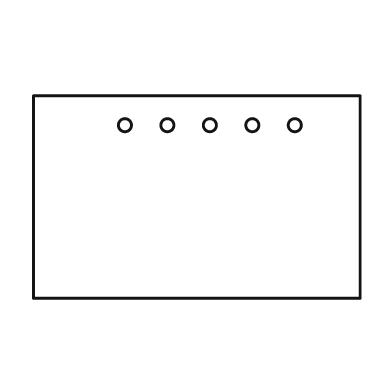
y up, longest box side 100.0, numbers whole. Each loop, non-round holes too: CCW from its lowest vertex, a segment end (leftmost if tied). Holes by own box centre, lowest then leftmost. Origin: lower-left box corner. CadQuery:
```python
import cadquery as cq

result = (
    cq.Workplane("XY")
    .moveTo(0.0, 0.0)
    .lineTo(100.0, 0.0)
    .lineTo(100.0, 62.0)
    .lineTo(0.0, 62.0)
    .close()
    .moveTo(28.0, 53.0)
    .circle(2.0)
    .moveTo(41.0, 53.0)
    .circle(2.0)
    .moveTo(54.0, 53.0)
    .circle(2.0)
    .moveTo(67.0, 53.0)
    .circle(2.0)
    .moveTo(80.0, 53.0)
    .circle(2.0)
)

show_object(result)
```